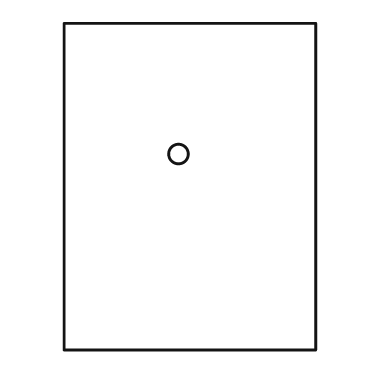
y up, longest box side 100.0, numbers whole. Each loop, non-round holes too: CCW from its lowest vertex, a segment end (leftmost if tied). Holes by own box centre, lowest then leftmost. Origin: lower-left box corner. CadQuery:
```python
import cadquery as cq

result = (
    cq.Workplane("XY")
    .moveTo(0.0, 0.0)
    .lineTo(77.0, 0.0)
    .lineTo(77.0, 100.0)
    .lineTo(0.0, 100.0)
    .close()
    .moveTo(35.0, 60.0)
    .circle(3.0)
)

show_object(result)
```